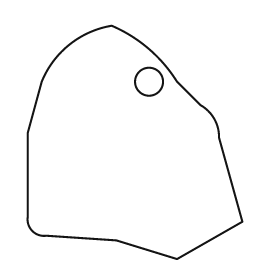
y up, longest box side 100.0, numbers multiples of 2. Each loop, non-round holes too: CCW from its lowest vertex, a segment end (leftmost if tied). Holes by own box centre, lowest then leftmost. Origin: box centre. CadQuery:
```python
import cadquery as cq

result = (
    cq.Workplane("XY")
    .moveTo(18.0, -50.0)
    .lineTo(46.0, -34.0)
    .lineTo(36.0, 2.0)
    .threePointArc((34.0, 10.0), (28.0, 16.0))
    .lineTo(18.0, 26.0)
    .threePointArc((6.0, 40.0), (-10.0, 50.0))
    .threePointArc((-28.0, 42.0), (-40.0, 26.0))
    .lineTo(-46.0, 4.0)
    .lineTo(-46.0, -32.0)
    .threePointArc((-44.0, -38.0), (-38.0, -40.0))
    .lineTo(-8.0, -42.0)
    .close()
    .moveTo(6.0, 26.0)
    .circle(6.0)
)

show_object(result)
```